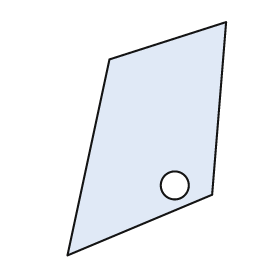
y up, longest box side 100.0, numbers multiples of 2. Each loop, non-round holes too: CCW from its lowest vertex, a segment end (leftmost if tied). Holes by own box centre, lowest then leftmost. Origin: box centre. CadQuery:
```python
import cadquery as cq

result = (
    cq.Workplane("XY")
    .moveTo(-34.0, -50.0)
    .lineTo(28.0, -24.0)
    .lineTo(34.0, 50.0)
    .lineTo(-16.0, 34.0)
    .close()
    .moveTo(12.0, -20.0)
    .circle(6.0)
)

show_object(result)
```